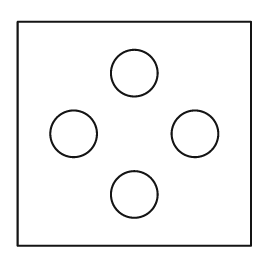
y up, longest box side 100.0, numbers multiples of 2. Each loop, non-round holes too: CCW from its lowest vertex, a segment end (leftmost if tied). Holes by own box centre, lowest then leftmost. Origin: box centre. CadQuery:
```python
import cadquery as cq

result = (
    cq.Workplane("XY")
    .moveTo(-50.0, -48.0)
    .lineTo(50.0, -48.0)
    .lineTo(50.0, 48.0)
    .lineTo(-50.0, 48.0)
    .close()
    .moveTo(0.0, -26.0)
    .circle(10.0)
    .moveTo(-26.0, 0.0)
    .circle(10.0)
    .moveTo(26.0, 0.0)
    .circle(10.0)
    .moveTo(0.0, 26.0)
    .circle(10.0)
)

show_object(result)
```